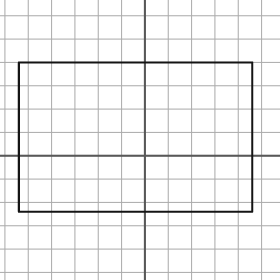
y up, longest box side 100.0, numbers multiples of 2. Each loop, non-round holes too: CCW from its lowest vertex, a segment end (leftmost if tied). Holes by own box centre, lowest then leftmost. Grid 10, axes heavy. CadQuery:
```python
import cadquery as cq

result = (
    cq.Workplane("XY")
    .moveTo(-54.0, -24.0)
    .lineTo(46.0, -24.0)
    .lineTo(46.0, 40.0)
    .lineTo(-54.0, 40.0)
    .close()
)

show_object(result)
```